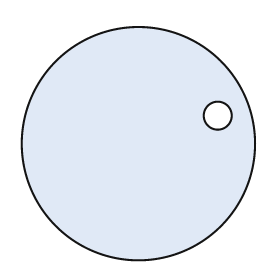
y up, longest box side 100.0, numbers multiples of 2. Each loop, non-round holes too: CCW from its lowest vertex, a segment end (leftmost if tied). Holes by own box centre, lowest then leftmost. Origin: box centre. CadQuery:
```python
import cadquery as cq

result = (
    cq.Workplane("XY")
    .moveTo(0.0, 0.0)
    .circle(50.0)
    .moveTo(34.0, 12.0)
    .circle(6.0)
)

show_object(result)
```